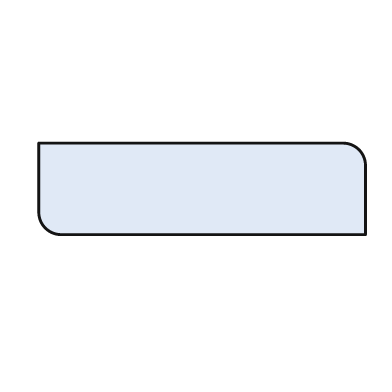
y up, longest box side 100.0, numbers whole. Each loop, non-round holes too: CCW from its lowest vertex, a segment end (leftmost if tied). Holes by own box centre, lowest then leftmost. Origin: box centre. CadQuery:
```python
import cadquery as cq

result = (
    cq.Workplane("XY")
    .moveTo(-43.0, -14.0)
    .lineTo(50.0, -14.0)
    .lineTo(50.0, 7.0)
    .threePointArc((48.0, 12.0), (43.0, 14.0))
    .lineTo(-50.0, 14.0)
    .lineTo(-50.0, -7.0)
    .threePointArc((-48.0, -12.0), (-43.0, -14.0))
    .close()
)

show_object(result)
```